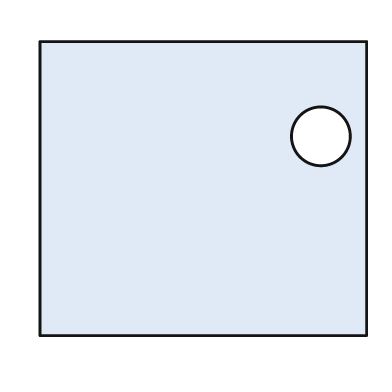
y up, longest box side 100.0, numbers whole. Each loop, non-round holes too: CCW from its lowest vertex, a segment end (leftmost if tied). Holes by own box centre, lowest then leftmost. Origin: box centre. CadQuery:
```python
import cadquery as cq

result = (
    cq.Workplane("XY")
    .moveTo(-50.0, -45.0)
    .lineTo(50.0, -45.0)
    .lineTo(50.0, 45.0)
    .lineTo(-50.0, 45.0)
    .close()
    .moveTo(36.0, 16.0)
    .circle(9.0)
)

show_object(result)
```